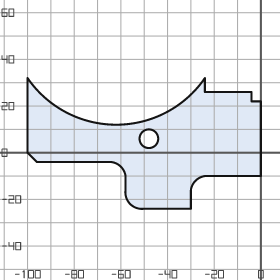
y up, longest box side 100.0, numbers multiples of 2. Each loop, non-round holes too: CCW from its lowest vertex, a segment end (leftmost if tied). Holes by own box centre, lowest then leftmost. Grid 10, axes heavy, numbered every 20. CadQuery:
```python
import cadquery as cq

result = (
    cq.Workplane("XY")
    .moveTo(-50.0, -24.0)
    .lineTo(-30.0, -24.0)
    .lineTo(-30.0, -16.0)
    .threePointArc((-28.0, -12.0), (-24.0, -10.0))
    .lineTo(0.0, -10.0)
    .lineTo(0.0, 22.0)
    .lineTo(-4.0, 22.0)
    .lineTo(-4.0, 26.0)
    .lineTo(-24.0, 26.0)
    .lineTo(-24.0, 32.0)
    .threePointArc((-62.0, 12.0), (-100.0, 32.0))
    .lineTo(-100.0, 0.0)
    .lineTo(-96.0, -4.0)
    .lineTo(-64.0, -4.0)
    .threePointArc((-60.0, -6.0), (-58.0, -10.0))
    .lineTo(-58.0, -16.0)
    .threePointArc((-56.0, -22.0), (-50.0, -24.0))
    .close()
    .moveTo(-48.0, 6.0)
    .circle(4.0)
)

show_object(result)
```